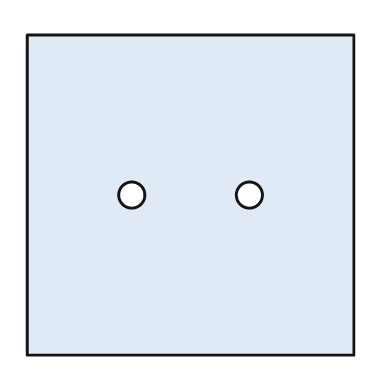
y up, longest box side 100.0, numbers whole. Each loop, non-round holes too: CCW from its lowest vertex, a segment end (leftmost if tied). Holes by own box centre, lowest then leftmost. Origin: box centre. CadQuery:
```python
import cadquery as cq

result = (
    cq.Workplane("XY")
    .moveTo(-50.0, -49.0)
    .lineTo(50.0, -49.0)
    .lineTo(50.0, 49.0)
    .lineTo(-50.0, 49.0)
    .close()
    .moveTo(-18.0, 0.0)
    .circle(4.0)
    .moveTo(18.0, 0.0)
    .circle(4.0)
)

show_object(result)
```